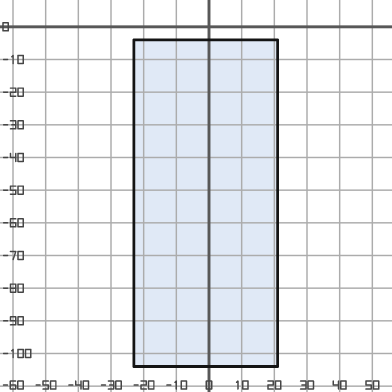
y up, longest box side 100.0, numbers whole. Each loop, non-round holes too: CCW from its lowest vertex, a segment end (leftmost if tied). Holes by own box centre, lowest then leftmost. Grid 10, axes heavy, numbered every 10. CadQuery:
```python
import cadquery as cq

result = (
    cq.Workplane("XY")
    .moveTo(-23.0, -104.0)
    .lineTo(21.0, -104.0)
    .lineTo(21.0, -4.0)
    .lineTo(-23.0, -4.0)
    .close()
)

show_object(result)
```